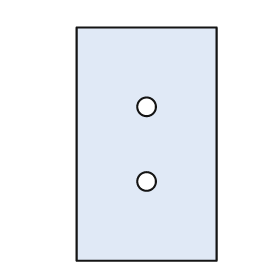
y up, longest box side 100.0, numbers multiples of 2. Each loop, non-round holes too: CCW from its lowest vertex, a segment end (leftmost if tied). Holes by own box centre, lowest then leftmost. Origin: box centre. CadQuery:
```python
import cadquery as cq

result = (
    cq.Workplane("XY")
    .moveTo(-30.0, -50.0)
    .lineTo(30.0, -50.0)
    .lineTo(30.0, 50.0)
    .lineTo(-30.0, 50.0)
    .close()
    .moveTo(0.0, -16.0)
    .circle(4.0)
    .moveTo(0.0, 16.0)
    .circle(4.0)
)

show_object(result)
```